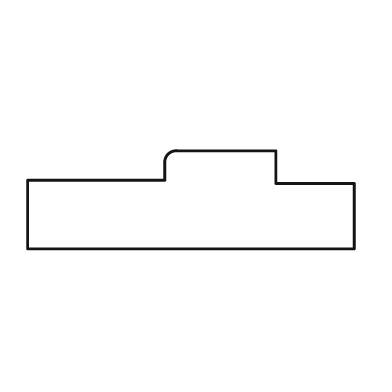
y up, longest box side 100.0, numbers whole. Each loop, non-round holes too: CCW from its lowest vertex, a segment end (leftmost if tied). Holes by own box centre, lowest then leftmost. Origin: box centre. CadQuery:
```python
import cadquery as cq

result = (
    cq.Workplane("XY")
    .moveTo(-50.0, -15.0)
    .lineTo(50.0, -15.0)
    .lineTo(50.0, 5.0)
    .lineTo(26.0, 5.0)
    .lineTo(26.0, 15.0)
    .lineTo(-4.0, 15.0)
    .threePointArc((-7.0, 14.0), (-8.0, 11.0))
    .lineTo(-8.0, 6.0)
    .lineTo(-50.0, 6.0)
    .close()
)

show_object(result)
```